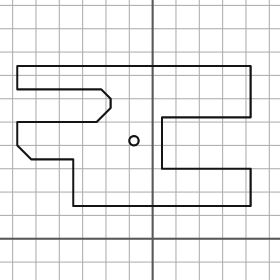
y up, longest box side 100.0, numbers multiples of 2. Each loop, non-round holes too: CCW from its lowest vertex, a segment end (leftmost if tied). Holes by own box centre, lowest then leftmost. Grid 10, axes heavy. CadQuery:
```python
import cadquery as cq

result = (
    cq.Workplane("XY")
    .moveTo(-34.0, 14.0)
    .lineTo(42.0, 14.0)
    .lineTo(42.0, 30.0)
    .lineTo(4.0, 30.0)
    .lineTo(4.0, 52.0)
    .lineTo(42.0, 52.0)
    .lineTo(42.0, 74.0)
    .lineTo(-58.0, 74.0)
    .lineTo(-58.0, 64.0)
    .lineTo(-22.0, 64.0)
    .lineTo(-18.0, 60.0)
    .lineTo(-18.0, 56.0)
    .lineTo(-24.0, 50.0)
    .lineTo(-58.0, 50.0)
    .lineTo(-58.0, 40.0)
    .lineTo(-52.0, 34.0)
    .lineTo(-34.0, 34.0)
    .close()
    .moveTo(-8.0, 42.0)
    .circle(2.0)
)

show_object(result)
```